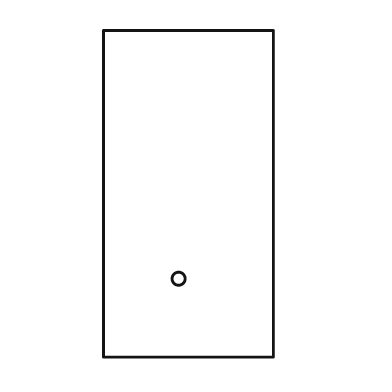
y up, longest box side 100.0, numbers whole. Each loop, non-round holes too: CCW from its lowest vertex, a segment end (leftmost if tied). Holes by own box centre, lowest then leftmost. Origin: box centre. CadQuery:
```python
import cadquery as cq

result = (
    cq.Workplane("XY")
    .moveTo(-26.0, -50.0)
    .lineTo(26.0, -50.0)
    .lineTo(26.0, 50.0)
    .lineTo(-26.0, 50.0)
    .close()
    .moveTo(-3.0, -26.0)
    .circle(2.0)
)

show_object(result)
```